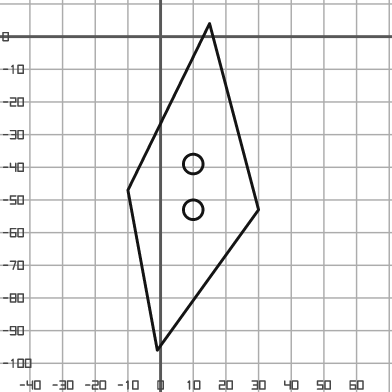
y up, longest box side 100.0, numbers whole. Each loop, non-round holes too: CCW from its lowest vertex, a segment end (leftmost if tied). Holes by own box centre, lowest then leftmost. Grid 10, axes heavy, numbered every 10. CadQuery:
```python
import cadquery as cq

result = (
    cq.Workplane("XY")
    .moveTo(-1.0, -96.0)
    .lineTo(30.0, -53.0)
    .lineTo(15.0, 4.0)
    .lineTo(-10.0, -47.0)
    .close()
    .moveTo(10.0, -53.0)
    .circle(3.0)
    .moveTo(10.0, -39.0)
    .circle(3.0)
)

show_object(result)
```